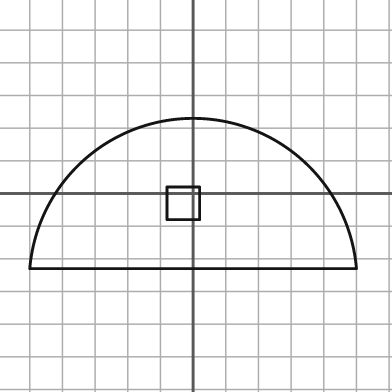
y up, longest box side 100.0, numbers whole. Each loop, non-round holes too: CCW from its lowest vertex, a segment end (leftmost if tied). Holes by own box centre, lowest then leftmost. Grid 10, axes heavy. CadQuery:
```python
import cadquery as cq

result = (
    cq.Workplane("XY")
    .moveTo(-50.0, -23.0)
    .lineTo(50.0, -23.0)
    .threePointArc((0.0, 23.0), (-50.0, -23.0))
    .close()
    .moveTo(-8.0, -8.0)
    .lineTo(2.0, -8.0)
    .lineTo(2.0, 2.0)
    .lineTo(-8.0, 2.0)
    .close()
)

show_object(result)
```